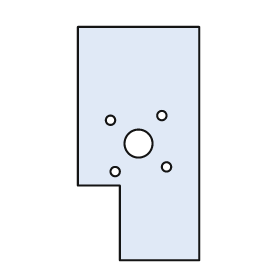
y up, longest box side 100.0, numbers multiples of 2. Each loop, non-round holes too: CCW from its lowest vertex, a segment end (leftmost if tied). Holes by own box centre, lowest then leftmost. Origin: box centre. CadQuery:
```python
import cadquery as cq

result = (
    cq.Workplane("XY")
    .moveTo(-8.0, -50.0)
    .lineTo(26.0, -50.0)
    .lineTo(26.0, 50.0)
    .lineTo(-26.0, 50.0)
    .lineTo(-26.0, -18.0)
    .lineTo(-8.0, -18.0)
    .close()
    .moveTo(-10.0, -12.0)
    .circle(2.0)
    .moveTo(12.0, -10.0)
    .circle(2.0)
    .moveTo(0.0, 0.0)
    .circle(6.0)
    .moveTo(-12.0, 10.0)
    .circle(2.0)
    .moveTo(10.0, 12.0)
    .circle(2.0)
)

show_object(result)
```